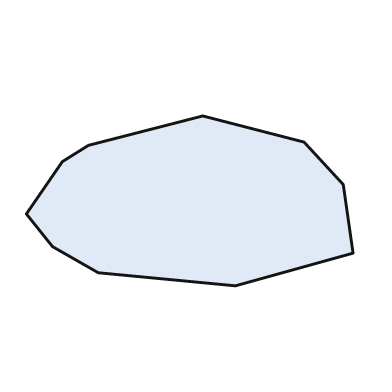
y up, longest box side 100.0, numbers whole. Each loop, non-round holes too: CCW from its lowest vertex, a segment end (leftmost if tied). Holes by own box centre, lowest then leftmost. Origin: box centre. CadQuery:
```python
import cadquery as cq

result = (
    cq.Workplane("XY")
    .moveTo(14.0, -26.0)
    .lineTo(50.0, -16.0)
    .lineTo(47.0, 5.0)
    .lineTo(35.0, 18.0)
    .lineTo(4.0, 26.0)
    .lineTo(-31.0, 17.0)
    .lineTo(-39.0, 12.0)
    .lineTo(-50.0, -4.0)
    .lineTo(-42.0, -14.0)
    .lineTo(-28.0, -22.0)
    .close()
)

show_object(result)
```